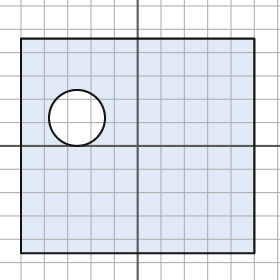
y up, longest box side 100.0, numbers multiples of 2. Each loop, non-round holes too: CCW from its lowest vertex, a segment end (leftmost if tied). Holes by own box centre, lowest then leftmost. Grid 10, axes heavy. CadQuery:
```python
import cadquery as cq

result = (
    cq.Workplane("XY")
    .moveTo(-50.0, -46.0)
    .lineTo(50.0, -46.0)
    .lineTo(50.0, 46.0)
    .lineTo(-50.0, 46.0)
    .close()
    .moveTo(-26.0, 12.0)
    .circle(12.0)
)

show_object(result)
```